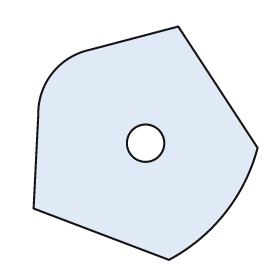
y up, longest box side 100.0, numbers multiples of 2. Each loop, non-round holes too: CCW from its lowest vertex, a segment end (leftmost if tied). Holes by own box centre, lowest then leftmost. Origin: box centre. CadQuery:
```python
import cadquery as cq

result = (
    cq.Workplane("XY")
    .moveTo(10.0, -50.0)
    .threePointArc((34.0, -30.0), (48.0, -2.0))
    .lineTo(14.0, 50.0)
    .lineTo(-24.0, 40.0)
    .threePointArc((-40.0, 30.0), (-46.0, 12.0))
    .lineTo(-48.0, -28.0)
    .close()
    .moveTo(0.0, 0.0)
    .circle(8.0)
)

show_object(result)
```